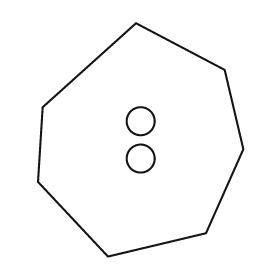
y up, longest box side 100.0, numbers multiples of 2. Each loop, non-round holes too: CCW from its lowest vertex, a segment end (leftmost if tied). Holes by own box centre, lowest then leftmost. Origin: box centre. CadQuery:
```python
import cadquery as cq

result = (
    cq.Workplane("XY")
    .moveTo(-14.0, -50.0)
    .lineTo(28.0, -40.0)
    .lineTo(44.0, -4.0)
    .lineTo(36.0, 30.0)
    .lineTo(-2.0, 50.0)
    .lineTo(-42.0, 14.0)
    .lineTo(-44.0, -18.0)
    .close()
    .moveTo(0.0, -8.0)
    .circle(6.0)
    .moveTo(0.0, 8.0)
    .circle(6.0)
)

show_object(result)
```